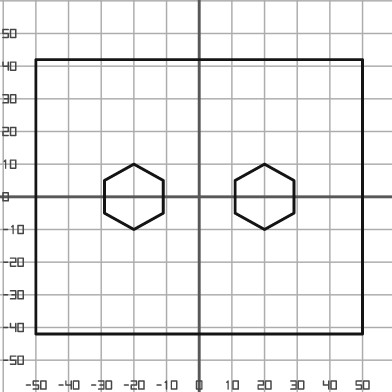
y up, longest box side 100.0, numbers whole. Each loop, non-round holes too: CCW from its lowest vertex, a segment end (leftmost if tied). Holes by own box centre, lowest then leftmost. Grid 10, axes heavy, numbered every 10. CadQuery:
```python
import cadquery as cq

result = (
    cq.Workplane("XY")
    .moveTo(-50.0, -42.0)
    .lineTo(50.0, -42.0)
    .lineTo(50.0, 42.0)
    .lineTo(-50.0, 42.0)
    .close()
    .moveTo(-20.0, -10.0)
    .lineTo(-11.0, -5.0)
    .lineTo(-11.0, 5.0)
    .lineTo(-20.0, 10.0)
    .lineTo(-29.0, 5.0)
    .lineTo(-29.0, -5.0)
    .close()
    .moveTo(20.0, -10.0)
    .lineTo(29.0, -5.0)
    .lineTo(29.0, 5.0)
    .lineTo(20.0, 10.0)
    .lineTo(11.0, 5.0)
    .lineTo(11.0, -5.0)
    .close()
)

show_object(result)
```